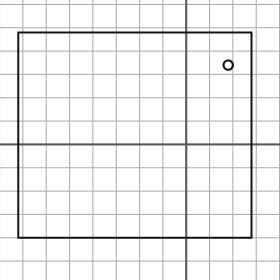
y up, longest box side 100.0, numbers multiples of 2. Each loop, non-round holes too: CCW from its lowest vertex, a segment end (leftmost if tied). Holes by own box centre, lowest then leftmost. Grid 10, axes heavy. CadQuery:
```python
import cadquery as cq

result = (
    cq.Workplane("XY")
    .moveTo(-72.0, -40.0)
    .lineTo(28.0, -40.0)
    .lineTo(28.0, 48.0)
    .lineTo(-72.0, 48.0)
    .close()
    .moveTo(18.0, 34.0)
    .circle(2.0)
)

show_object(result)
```